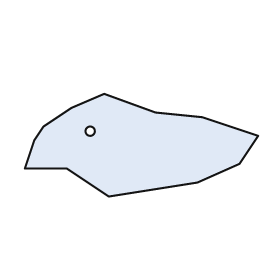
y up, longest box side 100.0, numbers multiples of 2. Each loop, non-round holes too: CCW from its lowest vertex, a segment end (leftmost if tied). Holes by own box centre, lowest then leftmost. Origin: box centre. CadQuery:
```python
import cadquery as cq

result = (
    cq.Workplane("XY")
    .moveTo(-14.0, -22.0)
    .lineTo(24.0, -16.0)
    .lineTo(42.0, -8.0)
    .lineTo(50.0, 4.0)
    .lineTo(26.0, 12.0)
    .lineTo(6.0, 14.0)
    .lineTo(-16.0, 22.0)
    .lineTo(-30.0, 16.0)
    .lineTo(-42.0, 8.0)
    .lineTo(-46.0, 2.0)
    .lineTo(-50.0, -10.0)
    .lineTo(-32.0, -10.0)
    .close()
    .moveTo(-22.0, 6.0)
    .circle(2.0)
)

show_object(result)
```